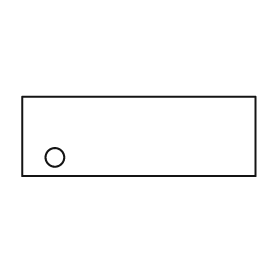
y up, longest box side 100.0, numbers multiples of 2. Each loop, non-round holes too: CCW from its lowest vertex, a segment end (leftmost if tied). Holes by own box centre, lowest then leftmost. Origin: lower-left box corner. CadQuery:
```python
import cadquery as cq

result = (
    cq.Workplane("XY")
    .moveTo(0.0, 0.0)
    .lineTo(100.0, 0.0)
    .lineTo(100.0, 34.0)
    .lineTo(0.0, 34.0)
    .close()
    .moveTo(14.0, 8.0)
    .circle(4.0)
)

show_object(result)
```